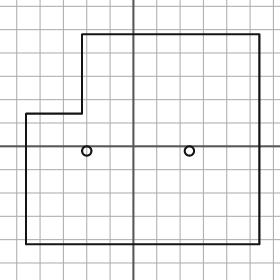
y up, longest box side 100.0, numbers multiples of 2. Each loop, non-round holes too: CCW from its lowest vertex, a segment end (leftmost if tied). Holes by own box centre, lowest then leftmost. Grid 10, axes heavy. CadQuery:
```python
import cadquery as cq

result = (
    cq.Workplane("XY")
    .moveTo(-46.0, -42.0)
    .lineTo(54.0, -42.0)
    .lineTo(54.0, 48.0)
    .lineTo(-22.0, 48.0)
    .lineTo(-22.0, 14.0)
    .lineTo(-46.0, 14.0)
    .close()
    .moveTo(-20.0, -2.0)
    .circle(2.0)
    .moveTo(24.0, -2.0)
    .circle(2.0)
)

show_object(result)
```